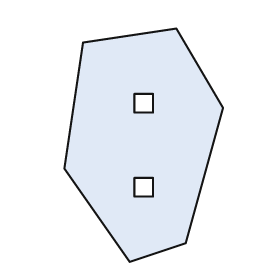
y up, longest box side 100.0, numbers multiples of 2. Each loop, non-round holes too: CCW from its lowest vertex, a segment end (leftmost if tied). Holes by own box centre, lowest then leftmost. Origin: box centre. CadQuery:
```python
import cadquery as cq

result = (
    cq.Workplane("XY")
    .moveTo(-6.0, -50.0)
    .lineTo(18.0, -42.0)
    .lineTo(34.0, 16.0)
    .lineTo(14.0, 50.0)
    .lineTo(-26.0, 44.0)
    .lineTo(-34.0, -10.0)
    .close()
    .moveTo(-4.0, -22.0)
    .lineTo(4.0, -22.0)
    .lineTo(4.0, -14.0)
    .lineTo(-4.0, -14.0)
    .close()
    .moveTo(-4.0, 14.0)
    .lineTo(4.0, 14.0)
    .lineTo(4.0, 22.0)
    .lineTo(-4.0, 22.0)
    .close()
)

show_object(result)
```